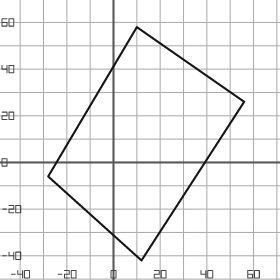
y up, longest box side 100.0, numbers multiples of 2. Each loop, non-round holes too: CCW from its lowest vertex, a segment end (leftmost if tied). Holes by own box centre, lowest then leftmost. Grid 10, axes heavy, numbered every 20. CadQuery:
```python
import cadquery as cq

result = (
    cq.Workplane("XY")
    .moveTo(12.0, -42.0)
    .lineTo(56.0, 26.0)
    .lineTo(10.0, 58.0)
    .lineTo(-28.0, -6.0)
    .close()
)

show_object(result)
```